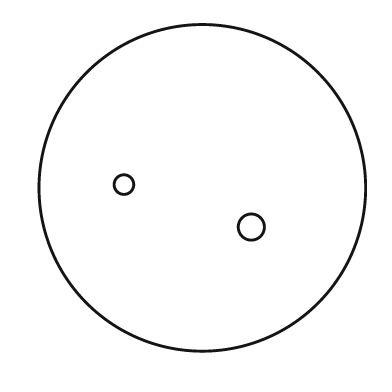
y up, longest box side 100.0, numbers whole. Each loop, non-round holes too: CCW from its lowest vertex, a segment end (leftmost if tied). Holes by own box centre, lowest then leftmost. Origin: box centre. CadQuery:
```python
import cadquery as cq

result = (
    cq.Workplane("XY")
    .moveTo(0.0, 0.0)
    .circle(50.0)
    .moveTo(15.0, -12.0)
    .circle(4.0)
    .moveTo(-24.0, 1.0)
    .circle(3.0)
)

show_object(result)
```